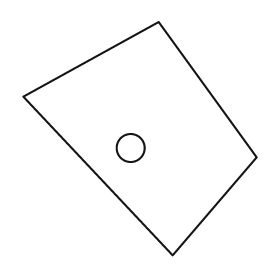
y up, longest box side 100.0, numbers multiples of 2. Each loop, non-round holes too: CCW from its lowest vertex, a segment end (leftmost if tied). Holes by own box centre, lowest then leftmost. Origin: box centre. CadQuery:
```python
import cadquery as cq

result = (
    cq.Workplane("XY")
    .moveTo(14.0, -50.0)
    .lineTo(50.0, -8.0)
    .lineTo(8.0, 50.0)
    .lineTo(-50.0, 18.0)
    .close()
    .moveTo(-4.0, -4.0)
    .circle(6.0)
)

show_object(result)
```